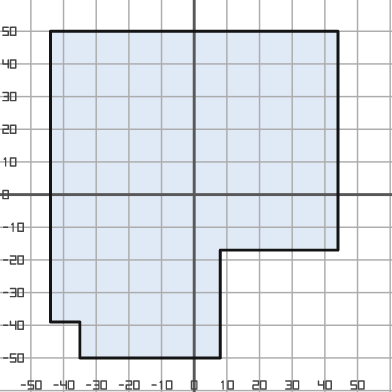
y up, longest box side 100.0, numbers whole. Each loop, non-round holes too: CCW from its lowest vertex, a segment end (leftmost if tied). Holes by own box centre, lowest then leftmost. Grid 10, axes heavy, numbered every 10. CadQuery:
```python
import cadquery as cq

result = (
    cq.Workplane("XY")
    .moveTo(-35.0, -50.0)
    .lineTo(8.0, -50.0)
    .lineTo(8.0, -17.0)
    .lineTo(44.0, -17.0)
    .lineTo(44.0, 50.0)
    .lineTo(-44.0, 50.0)
    .lineTo(-44.0, -39.0)
    .lineTo(-35.0, -39.0)
    .close()
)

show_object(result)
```